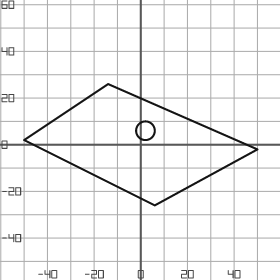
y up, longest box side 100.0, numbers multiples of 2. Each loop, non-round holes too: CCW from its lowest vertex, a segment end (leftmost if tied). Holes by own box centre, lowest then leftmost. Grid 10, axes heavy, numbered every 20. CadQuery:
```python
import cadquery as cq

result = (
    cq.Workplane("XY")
    .moveTo(6.0, -26.0)
    .lineTo(50.0, -2.0)
    .lineTo(-14.0, 26.0)
    .lineTo(-50.0, 2.0)
    .close()
    .moveTo(2.0, 6.0)
    .circle(4.0)
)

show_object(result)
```